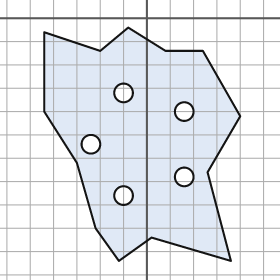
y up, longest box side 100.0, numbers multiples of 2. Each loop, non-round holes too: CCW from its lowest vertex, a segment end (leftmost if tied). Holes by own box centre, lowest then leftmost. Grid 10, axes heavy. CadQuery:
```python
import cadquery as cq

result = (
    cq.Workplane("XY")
    .moveTo(-12.0, -104.0)
    .lineTo(2.0, -94.0)
    .lineTo(36.0, -104.0)
    .lineTo(26.0, -66.0)
    .lineTo(40.0, -42.0)
    .lineTo(24.0, -14.0)
    .lineTo(8.0, -14.0)
    .lineTo(-8.0, -4.0)
    .lineTo(-20.0, -14.0)
    .lineTo(-44.0, -6.0)
    .lineTo(-44.0, -40.0)
    .lineTo(-30.0, -62.0)
    .lineTo(-22.0, -90.0)
    .close()
    .moveTo(-10.0, -76.0)
    .circle(4.0)
    .moveTo(16.0, -68.0)
    .circle(4.0)
    .moveTo(-24.0, -54.0)
    .circle(4.0)
    .moveTo(16.0, -40.0)
    .circle(4.0)
    .moveTo(-10.0, -32.0)
    .circle(4.0)
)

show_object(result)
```